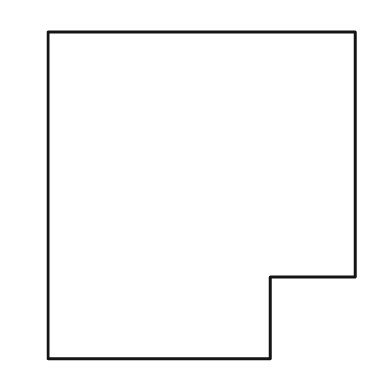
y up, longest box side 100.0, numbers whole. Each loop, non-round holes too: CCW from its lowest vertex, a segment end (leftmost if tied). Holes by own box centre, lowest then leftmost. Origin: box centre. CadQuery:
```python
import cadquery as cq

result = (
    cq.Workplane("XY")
    .moveTo(-47.0, -50.0)
    .lineTo(21.0, -50.0)
    .lineTo(21.0, -25.0)
    .lineTo(47.0, -25.0)
    .lineTo(47.0, 50.0)
    .lineTo(-47.0, 50.0)
    .close()
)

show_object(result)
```